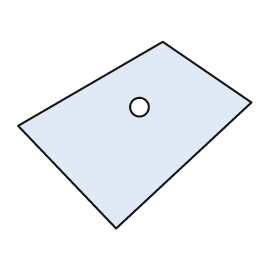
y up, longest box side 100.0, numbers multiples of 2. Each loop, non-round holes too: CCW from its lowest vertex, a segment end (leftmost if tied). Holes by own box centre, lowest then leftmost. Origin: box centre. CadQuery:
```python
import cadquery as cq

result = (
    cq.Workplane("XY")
    .moveTo(-8.0, -40.0)
    .lineTo(50.0, 14.0)
    .lineTo(12.0, 40.0)
    .lineTo(-50.0, 4.0)
    .close()
    .moveTo(2.0, 12.0)
    .circle(4.0)
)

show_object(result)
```